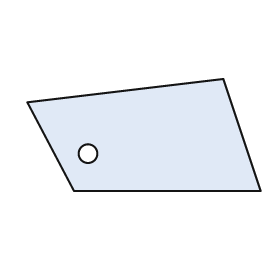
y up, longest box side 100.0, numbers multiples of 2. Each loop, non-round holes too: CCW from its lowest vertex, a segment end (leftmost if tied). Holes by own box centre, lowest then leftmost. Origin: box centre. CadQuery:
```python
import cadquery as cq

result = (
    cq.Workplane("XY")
    .moveTo(-30.0, -24.0)
    .lineTo(50.0, -24.0)
    .lineTo(34.0, 24.0)
    .lineTo(-50.0, 14.0)
    .close()
    .moveTo(-24.0, -8.0)
    .circle(4.0)
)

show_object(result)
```